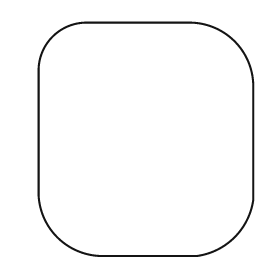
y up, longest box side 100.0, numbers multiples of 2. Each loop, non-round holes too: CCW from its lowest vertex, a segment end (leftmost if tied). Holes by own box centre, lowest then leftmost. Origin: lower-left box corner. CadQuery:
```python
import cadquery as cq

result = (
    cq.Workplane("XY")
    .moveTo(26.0, 0.0)
    .lineTo(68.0, 0.0)
    .threePointArc((84.0, 8.0), (92.0, 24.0))
    .lineTo(92.0, 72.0)
    .threePointArc((84.0, 92.0), (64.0, 100.0))
    .lineTo(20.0, 100.0)
    .threePointArc((6.0, 94.0), (0.0, 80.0))
    .lineTo(0.0, 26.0)
    .threePointArc((8.0, 8.0), (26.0, 0.0))
    .close()
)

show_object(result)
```